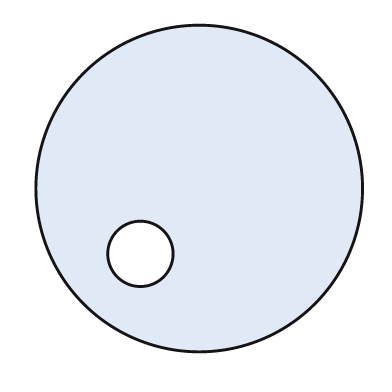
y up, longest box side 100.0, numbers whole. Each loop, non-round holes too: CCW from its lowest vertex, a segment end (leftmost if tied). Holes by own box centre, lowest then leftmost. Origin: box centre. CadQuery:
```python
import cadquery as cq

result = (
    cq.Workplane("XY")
    .moveTo(0.0, 0.0)
    .circle(50.0)
    .moveTo(-18.0, -20.0)
    .circle(10.0)
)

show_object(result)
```